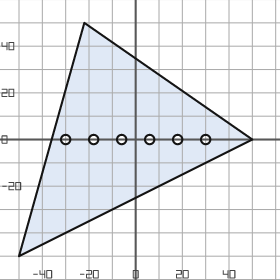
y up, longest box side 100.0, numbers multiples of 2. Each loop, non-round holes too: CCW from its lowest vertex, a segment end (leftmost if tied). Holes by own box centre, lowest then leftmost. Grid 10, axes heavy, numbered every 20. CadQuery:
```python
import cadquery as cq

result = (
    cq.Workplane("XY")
    .moveTo(-50.0, -50.0)
    .lineTo(50.0, 0.0)
    .lineTo(-22.0, 50.0)
    .close()
    .moveTo(-30.0, 0.0)
    .circle(2.0)
    .moveTo(-18.0, 0.0)
    .circle(2.0)
    .moveTo(-6.0, 0.0)
    .circle(2.0)
    .moveTo(6.0, 0.0)
    .circle(2.0)
    .moveTo(18.0, 0.0)
    .circle(2.0)
    .moveTo(30.0, 0.0)
    .circle(2.0)
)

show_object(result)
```